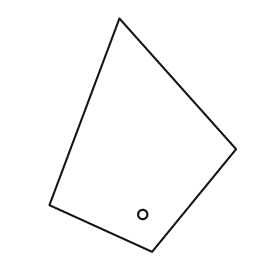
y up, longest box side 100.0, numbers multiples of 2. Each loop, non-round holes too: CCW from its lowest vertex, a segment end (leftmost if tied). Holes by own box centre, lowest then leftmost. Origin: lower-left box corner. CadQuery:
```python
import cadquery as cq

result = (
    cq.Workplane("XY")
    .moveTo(44.0, 0.0)
    .lineTo(80.0, 44.0)
    .lineTo(30.0, 100.0)
    .lineTo(0.0, 20.0)
    .close()
    .moveTo(40.0, 16.0)
    .circle(2.0)
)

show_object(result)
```